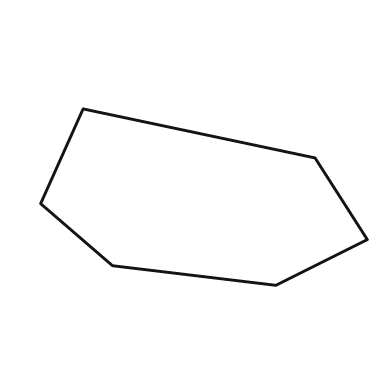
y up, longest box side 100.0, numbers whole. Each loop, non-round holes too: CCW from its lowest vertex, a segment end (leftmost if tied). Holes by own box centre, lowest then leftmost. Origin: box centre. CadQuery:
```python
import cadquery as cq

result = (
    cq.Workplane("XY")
    .moveTo(22.0, -27.0)
    .lineTo(50.0, -13.0)
    .lineTo(34.0, 12.0)
    .lineTo(-37.0, 27.0)
    .lineTo(-50.0, -2.0)
    .lineTo(-28.0, -21.0)
    .close()
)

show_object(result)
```